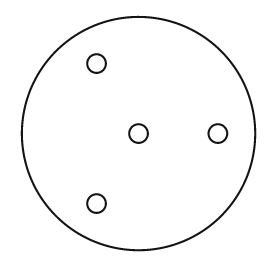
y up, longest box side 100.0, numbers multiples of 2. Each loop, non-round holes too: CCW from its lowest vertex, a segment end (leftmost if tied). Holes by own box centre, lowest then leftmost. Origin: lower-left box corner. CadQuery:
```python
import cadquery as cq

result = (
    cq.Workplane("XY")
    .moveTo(50.0, 50.0)
    .circle(50.0)
    .moveTo(32.0, 20.0)
    .circle(4.0)
    .moveTo(50.0, 50.0)
    .circle(4.0)
    .moveTo(84.0, 50.0)
    .circle(4.0)
    .moveTo(32.0, 80.0)
    .circle(4.0)
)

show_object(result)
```